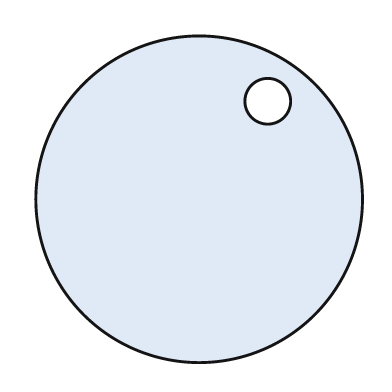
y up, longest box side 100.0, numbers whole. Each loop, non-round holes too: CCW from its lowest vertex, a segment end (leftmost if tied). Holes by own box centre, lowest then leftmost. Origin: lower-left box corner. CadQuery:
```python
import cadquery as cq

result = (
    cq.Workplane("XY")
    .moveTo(50.0, 50.0)
    .circle(50.0)
    .moveTo(71.0, 80.0)
    .circle(7.0)
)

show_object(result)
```